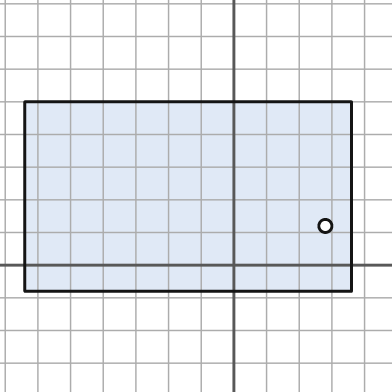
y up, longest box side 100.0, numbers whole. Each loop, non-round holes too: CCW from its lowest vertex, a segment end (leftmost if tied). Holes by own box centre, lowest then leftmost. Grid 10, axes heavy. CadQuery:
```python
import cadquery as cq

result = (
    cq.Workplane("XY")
    .moveTo(-64.0, -8.0)
    .lineTo(36.0, -8.0)
    .lineTo(36.0, 50.0)
    .lineTo(-64.0, 50.0)
    .close()
    .moveTo(28.0, 12.0)
    .circle(2.0)
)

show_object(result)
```